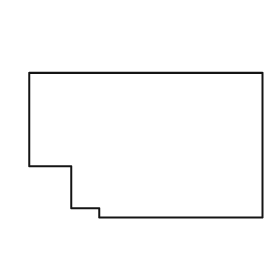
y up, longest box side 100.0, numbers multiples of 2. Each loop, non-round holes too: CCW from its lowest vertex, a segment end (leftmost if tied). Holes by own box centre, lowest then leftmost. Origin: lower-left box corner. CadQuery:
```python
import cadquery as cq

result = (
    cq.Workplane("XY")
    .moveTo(30.0, 0.0)
    .lineTo(100.0, 0.0)
    .lineTo(100.0, 62.0)
    .lineTo(0.0, 62.0)
    .lineTo(0.0, 22.0)
    .lineTo(18.0, 22.0)
    .lineTo(18.0, 4.0)
    .lineTo(30.0, 4.0)
    .close()
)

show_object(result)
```